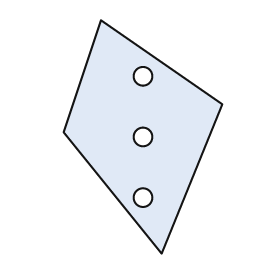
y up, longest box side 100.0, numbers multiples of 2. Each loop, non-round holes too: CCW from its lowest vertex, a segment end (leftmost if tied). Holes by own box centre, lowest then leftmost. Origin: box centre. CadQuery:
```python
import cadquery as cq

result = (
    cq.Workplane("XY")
    .moveTo(8.0, -50.0)
    .lineTo(34.0, 14.0)
    .lineTo(-18.0, 50.0)
    .lineTo(-34.0, 2.0)
    .close()
    .moveTo(0.0, -26.0)
    .circle(4.0)
    .moveTo(0.0, 0.0)
    .circle(4.0)
    .moveTo(0.0, 26.0)
    .circle(4.0)
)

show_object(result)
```